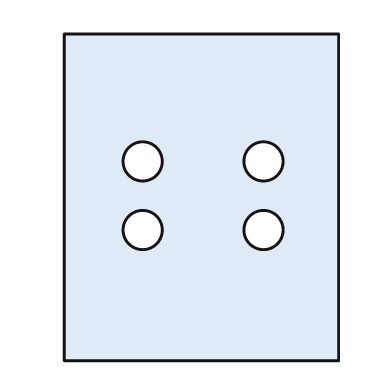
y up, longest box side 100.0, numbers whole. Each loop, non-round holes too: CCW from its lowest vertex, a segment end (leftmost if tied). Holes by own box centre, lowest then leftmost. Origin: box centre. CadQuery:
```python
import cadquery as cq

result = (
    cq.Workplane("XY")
    .moveTo(-42.0, -50.0)
    .lineTo(42.0, -50.0)
    .lineTo(42.0, 50.0)
    .lineTo(-42.0, 50.0)
    .close()
    .moveTo(-18.0, -10.0)
    .circle(6.0)
    .moveTo(19.0, -10.0)
    .circle(6.0)
    .moveTo(-18.0, 11.0)
    .circle(6.0)
    .moveTo(19.0, 11.0)
    .circle(6.0)
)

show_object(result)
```